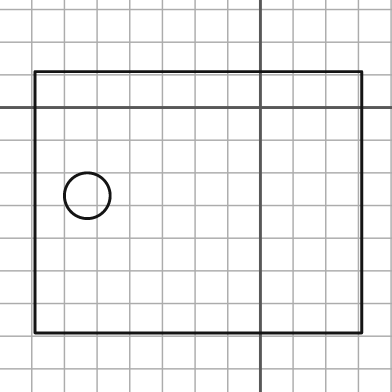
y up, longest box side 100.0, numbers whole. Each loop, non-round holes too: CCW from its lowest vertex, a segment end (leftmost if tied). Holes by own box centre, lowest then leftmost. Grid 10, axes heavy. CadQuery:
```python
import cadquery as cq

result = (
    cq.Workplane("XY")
    .moveTo(-69.0, -69.0)
    .lineTo(31.0, -69.0)
    .lineTo(31.0, 11.0)
    .lineTo(-69.0, 11.0)
    .close()
    .moveTo(-53.0, -27.0)
    .circle(7.0)
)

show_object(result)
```